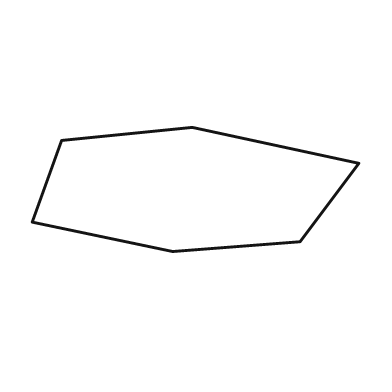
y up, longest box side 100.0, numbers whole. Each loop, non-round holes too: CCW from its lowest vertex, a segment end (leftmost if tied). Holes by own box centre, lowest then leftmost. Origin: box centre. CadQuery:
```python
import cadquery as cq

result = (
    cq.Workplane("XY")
    .moveTo(-7.0, -19.0)
    .lineTo(32.0, -16.0)
    .lineTo(50.0, 8.0)
    .lineTo(-1.0, 19.0)
    .lineTo(-41.0, 15.0)
    .lineTo(-50.0, -10.0)
    .close()
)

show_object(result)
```